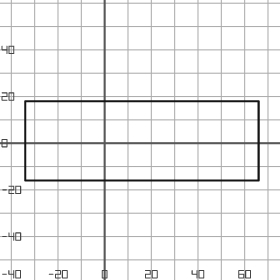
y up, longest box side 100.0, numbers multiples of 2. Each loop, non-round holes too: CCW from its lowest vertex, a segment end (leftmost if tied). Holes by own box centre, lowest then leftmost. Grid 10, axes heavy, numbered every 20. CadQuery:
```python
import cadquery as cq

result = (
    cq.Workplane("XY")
    .moveTo(-34.0, -16.0)
    .lineTo(66.0, -16.0)
    .lineTo(66.0, 18.0)
    .lineTo(-34.0, 18.0)
    .close()
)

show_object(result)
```